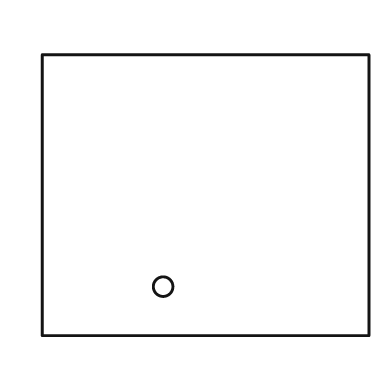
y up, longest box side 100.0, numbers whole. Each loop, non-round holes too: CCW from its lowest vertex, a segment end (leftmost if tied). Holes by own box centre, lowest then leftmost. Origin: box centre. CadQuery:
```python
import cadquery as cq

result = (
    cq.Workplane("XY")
    .moveTo(-50.0, -43.0)
    .lineTo(50.0, -43.0)
    .lineTo(50.0, 43.0)
    .lineTo(-50.0, 43.0)
    .close()
    .moveTo(-13.0, -28.0)
    .circle(3.0)
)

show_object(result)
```